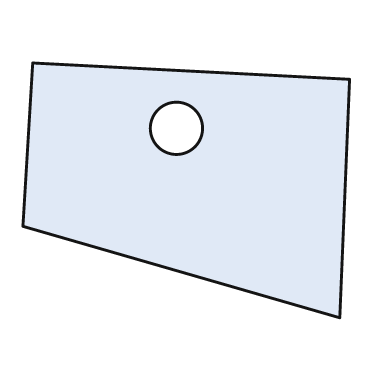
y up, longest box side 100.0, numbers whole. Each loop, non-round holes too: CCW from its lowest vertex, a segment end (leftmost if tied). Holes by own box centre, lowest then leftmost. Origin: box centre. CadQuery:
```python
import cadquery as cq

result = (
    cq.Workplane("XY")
    .moveTo(47.0, -39.0)
    .lineTo(50.0, 34.0)
    .lineTo(-47.0, 39.0)
    .lineTo(-50.0, -11.0)
    .close()
    .moveTo(-3.0, 19.0)
    .circle(8.0)
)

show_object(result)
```